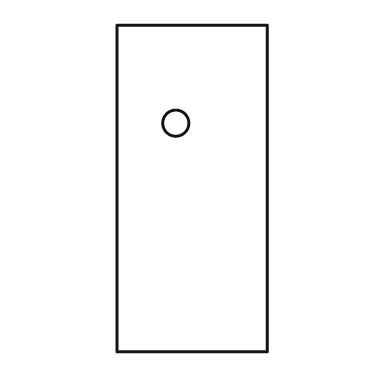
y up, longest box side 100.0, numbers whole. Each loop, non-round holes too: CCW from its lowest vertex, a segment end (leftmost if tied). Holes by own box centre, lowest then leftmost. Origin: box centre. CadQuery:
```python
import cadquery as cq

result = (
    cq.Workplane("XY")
    .moveTo(-23.0, -50.0)
    .lineTo(23.0, -50.0)
    .lineTo(23.0, 50.0)
    .lineTo(-23.0, 50.0)
    .close()
    .moveTo(-5.0, 20.0)
    .circle(4.0)
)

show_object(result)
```